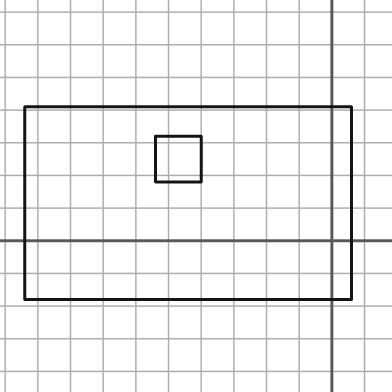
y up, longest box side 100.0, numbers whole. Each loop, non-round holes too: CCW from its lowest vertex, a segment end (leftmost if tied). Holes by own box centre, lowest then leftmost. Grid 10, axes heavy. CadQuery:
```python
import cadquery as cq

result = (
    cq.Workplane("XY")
    .moveTo(-94.0, -18.0)
    .lineTo(6.0, -18.0)
    .lineTo(6.0, 41.0)
    .lineTo(-94.0, 41.0)
    .close()
    .moveTo(-54.0, 18.0)
    .lineTo(-40.0, 18.0)
    .lineTo(-40.0, 32.0)
    .lineTo(-54.0, 32.0)
    .close()
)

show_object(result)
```